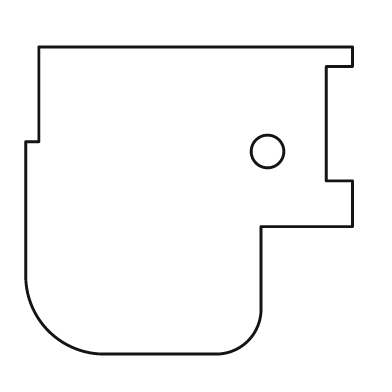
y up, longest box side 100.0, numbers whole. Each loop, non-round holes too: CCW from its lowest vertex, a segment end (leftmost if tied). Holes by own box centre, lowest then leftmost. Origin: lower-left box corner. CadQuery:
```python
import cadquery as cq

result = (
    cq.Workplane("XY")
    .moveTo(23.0, 0.0)
    .lineTo(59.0, 0.0)
    .threePointArc((68.0, 4.0), (72.0, 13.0))
    .lineTo(72.0, 39.0)
    .lineTo(100.0, 39.0)
    .lineTo(100.0, 53.0)
    .lineTo(92.0, 53.0)
    .lineTo(92.0, 88.0)
    .lineTo(100.0, 88.0)
    .lineTo(100.0, 94.0)
    .lineTo(4.0, 94.0)
    .lineTo(4.0, 65.0)
    .lineTo(0.0, 65.0)
    .lineTo(0.0, 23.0)
    .threePointArc((7.0, 7.0), (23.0, 0.0))
    .close()
    .moveTo(74.0, 62.0)
    .circle(5.0)
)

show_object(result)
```